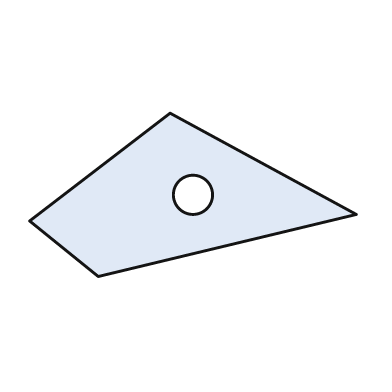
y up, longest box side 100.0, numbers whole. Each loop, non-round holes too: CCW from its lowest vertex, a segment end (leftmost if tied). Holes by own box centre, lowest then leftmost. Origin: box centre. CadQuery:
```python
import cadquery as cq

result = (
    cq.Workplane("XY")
    .moveTo(-29.0, -25.0)
    .lineTo(50.0, -6.0)
    .lineTo(-7.0, 25.0)
    .lineTo(-50.0, -8.0)
    .close()
    .moveTo(0.0, 0.0)
    .circle(6.0)
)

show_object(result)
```